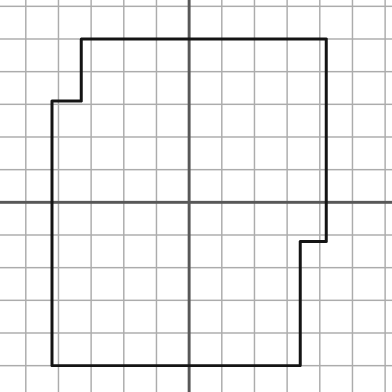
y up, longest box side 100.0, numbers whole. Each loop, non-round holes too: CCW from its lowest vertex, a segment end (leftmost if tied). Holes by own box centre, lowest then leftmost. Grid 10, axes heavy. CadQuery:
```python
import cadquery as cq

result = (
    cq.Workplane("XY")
    .moveTo(-42.0, -50.0)
    .lineTo(34.0, -50.0)
    .lineTo(34.0, -12.0)
    .lineTo(42.0, -12.0)
    .lineTo(42.0, 50.0)
    .lineTo(-33.0, 50.0)
    .lineTo(-33.0, 31.0)
    .lineTo(-42.0, 31.0)
    .close()
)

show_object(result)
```